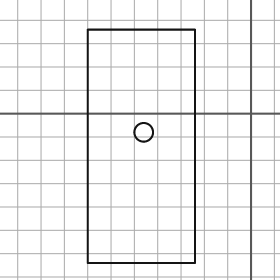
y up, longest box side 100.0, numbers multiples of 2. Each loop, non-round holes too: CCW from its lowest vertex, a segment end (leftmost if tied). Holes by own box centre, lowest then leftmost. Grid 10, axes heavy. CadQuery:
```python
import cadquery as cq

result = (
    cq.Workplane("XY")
    .moveTo(-70.0, -64.0)
    .lineTo(-24.0, -64.0)
    .lineTo(-24.0, 36.0)
    .lineTo(-70.0, 36.0)
    .close()
    .moveTo(-46.0, -8.0)
    .circle(4.0)
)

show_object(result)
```